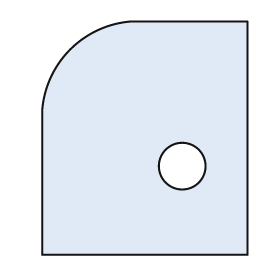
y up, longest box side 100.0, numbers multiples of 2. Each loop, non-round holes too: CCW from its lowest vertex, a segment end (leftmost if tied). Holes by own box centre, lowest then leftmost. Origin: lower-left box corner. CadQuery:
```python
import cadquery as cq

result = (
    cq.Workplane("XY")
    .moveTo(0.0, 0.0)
    .lineTo(88.0, 0.0)
    .lineTo(88.0, 100.0)
    .lineTo(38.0, 100.0)
    .threePointArc((12.0, 88.0), (0.0, 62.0))
    .close()
    .moveTo(60.0, 38.0)
    .circle(10.0)
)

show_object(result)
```